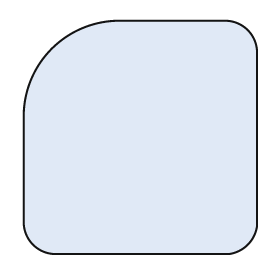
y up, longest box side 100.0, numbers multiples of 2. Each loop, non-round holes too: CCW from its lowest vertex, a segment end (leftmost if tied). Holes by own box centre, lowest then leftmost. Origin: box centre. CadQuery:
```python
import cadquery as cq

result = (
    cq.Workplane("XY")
    .moveTo(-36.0, -50.0)
    .lineTo(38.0, -50.0)
    .threePointArc((46.0, -46.0), (50.0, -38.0))
    .lineTo(50.0, 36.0)
    .threePointArc((46.0, 46.0), (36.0, 50.0))
    .lineTo(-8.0, 50.0)
    .threePointArc((-38.0, 38.0), (-50.0, 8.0))
    .lineTo(-50.0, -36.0)
    .threePointArc((-46.0, -46.0), (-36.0, -50.0))
    .close()
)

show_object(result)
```